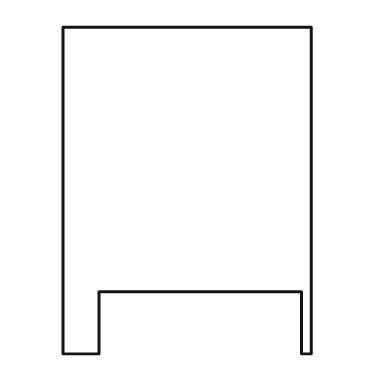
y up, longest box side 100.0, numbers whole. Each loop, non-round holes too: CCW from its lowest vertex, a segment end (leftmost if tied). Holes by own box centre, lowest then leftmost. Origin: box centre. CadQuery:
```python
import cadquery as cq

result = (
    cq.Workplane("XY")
    .moveTo(-38.0, -50.0)
    .lineTo(-27.0, -50.0)
    .lineTo(-27.0, -31.0)
    .lineTo(35.0, -31.0)
    .lineTo(35.0, -50.0)
    .lineTo(38.0, -50.0)
    .lineTo(38.0, 50.0)
    .lineTo(-38.0, 50.0)
    .close()
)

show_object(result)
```